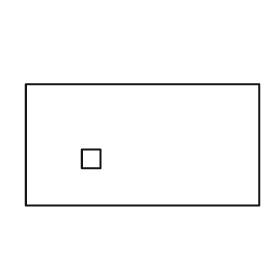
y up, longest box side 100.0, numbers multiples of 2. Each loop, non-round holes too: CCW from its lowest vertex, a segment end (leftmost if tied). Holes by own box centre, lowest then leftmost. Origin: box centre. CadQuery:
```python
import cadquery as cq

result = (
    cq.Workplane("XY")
    .moveTo(-50.0, -26.0)
    .lineTo(50.0, -26.0)
    .lineTo(50.0, 26.0)
    .lineTo(-50.0, 26.0)
    .close()
    .moveTo(-26.0, -10.0)
    .lineTo(-18.0, -10.0)
    .lineTo(-18.0, -2.0)
    .lineTo(-26.0, -2.0)
    .close()
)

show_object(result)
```